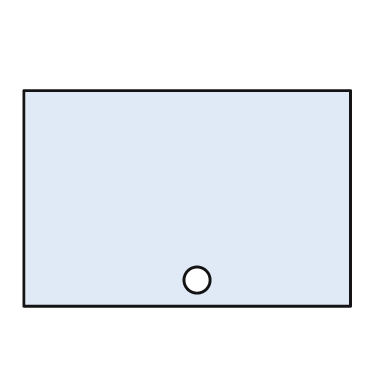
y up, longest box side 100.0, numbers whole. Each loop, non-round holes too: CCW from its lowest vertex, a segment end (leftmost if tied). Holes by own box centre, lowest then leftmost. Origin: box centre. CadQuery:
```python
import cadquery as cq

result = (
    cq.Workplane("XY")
    .moveTo(-50.0, -33.0)
    .lineTo(50.0, -33.0)
    .lineTo(50.0, 33.0)
    .lineTo(-50.0, 33.0)
    .close()
    .moveTo(3.0, -25.0)
    .circle(4.0)
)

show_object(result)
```